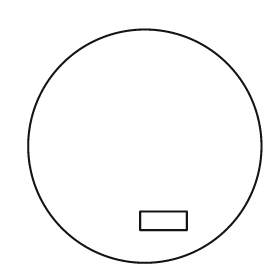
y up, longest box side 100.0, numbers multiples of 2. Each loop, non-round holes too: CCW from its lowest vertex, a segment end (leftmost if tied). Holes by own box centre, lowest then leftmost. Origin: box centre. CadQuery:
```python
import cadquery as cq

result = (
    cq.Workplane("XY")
    .moveTo(0.0, 0.0)
    .circle(50.0)
    .moveTo(-2.0, -36.0)
    .lineTo(18.0, -36.0)
    .lineTo(18.0, -28.0)
    .lineTo(-2.0, -28.0)
    .close()
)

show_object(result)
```